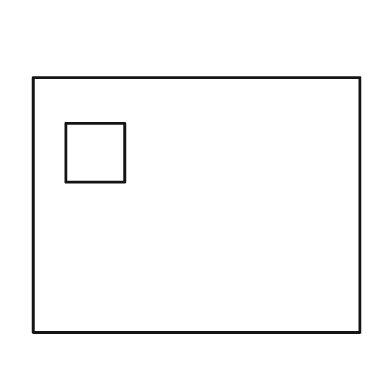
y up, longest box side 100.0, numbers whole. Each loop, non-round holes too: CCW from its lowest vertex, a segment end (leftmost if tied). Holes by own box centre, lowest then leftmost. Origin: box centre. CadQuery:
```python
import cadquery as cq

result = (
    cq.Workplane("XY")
    .moveTo(-50.0, -39.0)
    .lineTo(50.0, -39.0)
    .lineTo(50.0, 39.0)
    .lineTo(-50.0, 39.0)
    .close()
    .moveTo(-40.0, 7.0)
    .lineTo(-22.0, 7.0)
    .lineTo(-22.0, 25.0)
    .lineTo(-40.0, 25.0)
    .close()
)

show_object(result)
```